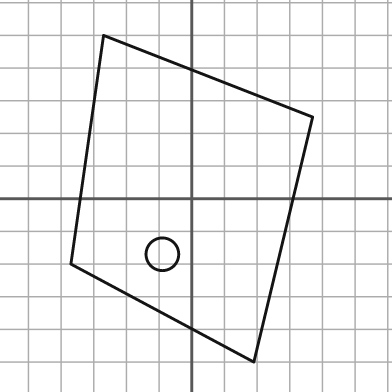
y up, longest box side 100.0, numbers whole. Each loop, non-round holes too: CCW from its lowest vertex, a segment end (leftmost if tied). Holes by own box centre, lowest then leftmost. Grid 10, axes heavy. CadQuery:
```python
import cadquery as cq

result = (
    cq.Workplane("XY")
    .moveTo(19.0, -50.0)
    .lineTo(37.0, 25.0)
    .lineTo(-27.0, 50.0)
    .lineTo(-37.0, -20.0)
    .close()
    .moveTo(-9.0, -17.0)
    .circle(5.0)
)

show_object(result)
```